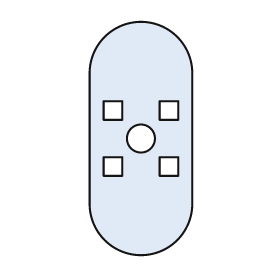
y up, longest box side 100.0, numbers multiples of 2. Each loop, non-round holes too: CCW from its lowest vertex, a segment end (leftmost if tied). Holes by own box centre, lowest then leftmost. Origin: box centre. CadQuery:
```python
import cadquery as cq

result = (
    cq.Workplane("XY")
    .moveTo(-22.0, -28.0)
    .threePointArc((0.0, -50.0), (22.0, -28.0))
    .lineTo(22.0, 28.0)
    .threePointArc((0.0, 50.0), (-22.0, 28.0))
    .close()
    .moveTo(-16.0, -16.0)
    .lineTo(-8.0, -16.0)
    .lineTo(-8.0, -8.0)
    .lineTo(-16.0, -8.0)
    .close()
    .moveTo(8.0, -16.0)
    .lineTo(16.0, -16.0)
    .lineTo(16.0, -8.0)
    .lineTo(8.0, -8.0)
    .close()
    .moveTo(0.0, 0.0)
    .circle(6.0)
    .moveTo(-16.0, 8.0)
    .lineTo(-8.0, 8.0)
    .lineTo(-8.0, 16.0)
    .lineTo(-16.0, 16.0)
    .close()
    .moveTo(8.0, 8.0)
    .lineTo(16.0, 8.0)
    .lineTo(16.0, 16.0)
    .lineTo(8.0, 16.0)
    .close()
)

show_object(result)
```